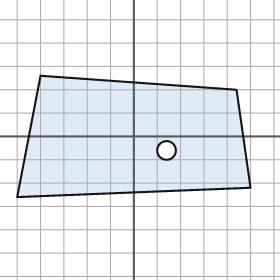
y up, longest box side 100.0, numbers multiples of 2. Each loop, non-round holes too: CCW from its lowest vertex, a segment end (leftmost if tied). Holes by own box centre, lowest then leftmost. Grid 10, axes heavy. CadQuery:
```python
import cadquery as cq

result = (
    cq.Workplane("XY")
    .moveTo(-50.0, -26.0)
    .lineTo(50.0, -22.0)
    .lineTo(44.0, 20.0)
    .lineTo(-40.0, 26.0)
    .close()
    .moveTo(14.0, -6.0)
    .circle(4.0)
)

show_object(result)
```